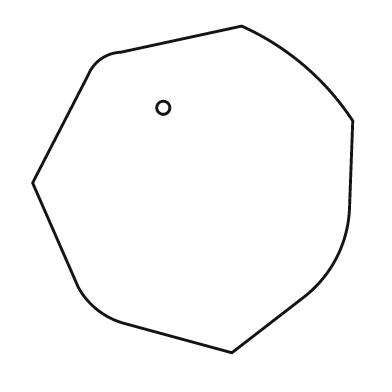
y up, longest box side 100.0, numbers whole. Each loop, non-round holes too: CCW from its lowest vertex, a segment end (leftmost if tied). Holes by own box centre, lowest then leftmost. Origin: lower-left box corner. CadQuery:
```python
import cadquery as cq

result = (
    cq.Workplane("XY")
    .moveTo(61.0, 0.0)
    .lineTo(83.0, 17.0)
    .threePointArc((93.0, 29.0), (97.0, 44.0))
    .lineTo(98.0, 71.0)
    .threePointArc((83.0, 88.0), (64.0, 100.0))
    .lineTo(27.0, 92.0)
    .threePointArc((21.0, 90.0), (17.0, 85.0))
    .lineTo(0.0, 52.0)
    .lineTo(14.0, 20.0)
    .threePointArc((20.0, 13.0), (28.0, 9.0))
    .close()
    .moveTo(40.0, 75.0)
    .circle(2.0)
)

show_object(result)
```